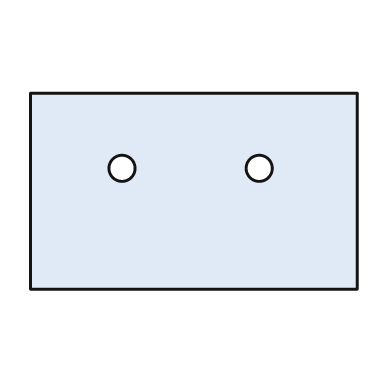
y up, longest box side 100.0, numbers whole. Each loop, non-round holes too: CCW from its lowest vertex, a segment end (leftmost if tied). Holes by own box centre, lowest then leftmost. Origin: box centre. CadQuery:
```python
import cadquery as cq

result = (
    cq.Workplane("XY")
    .moveTo(-50.0, -30.0)
    .lineTo(50.0, -30.0)
    .lineTo(50.0, 30.0)
    .lineTo(-50.0, 30.0)
    .close()
    .moveTo(-22.0, 7.0)
    .circle(4.0)
    .moveTo(20.0, 7.0)
    .circle(4.0)
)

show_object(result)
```